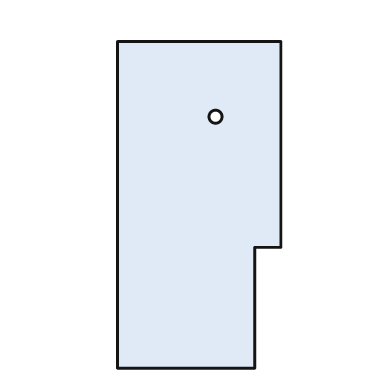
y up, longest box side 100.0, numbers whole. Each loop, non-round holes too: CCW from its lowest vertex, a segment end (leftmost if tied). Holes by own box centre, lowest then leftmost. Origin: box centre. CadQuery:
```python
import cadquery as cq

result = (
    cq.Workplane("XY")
    .moveTo(-25.0, -50.0)
    .lineTo(17.0, -50.0)
    .lineTo(17.0, -13.0)
    .lineTo(25.0, -13.0)
    .lineTo(25.0, 50.0)
    .lineTo(-25.0, 50.0)
    .close()
    .moveTo(5.0, 27.0)
    .circle(2.0)
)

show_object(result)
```